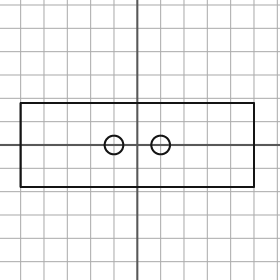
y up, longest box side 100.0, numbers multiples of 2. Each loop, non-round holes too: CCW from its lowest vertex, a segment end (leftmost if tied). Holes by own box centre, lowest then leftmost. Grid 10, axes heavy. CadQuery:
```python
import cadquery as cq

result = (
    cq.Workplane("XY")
    .moveTo(-50.0, -18.0)
    .lineTo(50.0, -18.0)
    .lineTo(50.0, 18.0)
    .lineTo(-50.0, 18.0)
    .close()
    .moveTo(-10.0, 0.0)
    .circle(4.0)
    .moveTo(10.0, 0.0)
    .circle(4.0)
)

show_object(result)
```